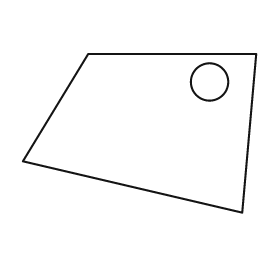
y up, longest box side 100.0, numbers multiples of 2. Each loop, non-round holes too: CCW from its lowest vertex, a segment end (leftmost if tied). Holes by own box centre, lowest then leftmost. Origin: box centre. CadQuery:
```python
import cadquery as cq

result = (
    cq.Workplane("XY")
    .moveTo(44.0, -34.0)
    .lineTo(50.0, 34.0)
    .lineTo(-22.0, 34.0)
    .lineTo(-50.0, -12.0)
    .close()
    .moveTo(30.0, 22.0)
    .circle(8.0)
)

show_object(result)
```